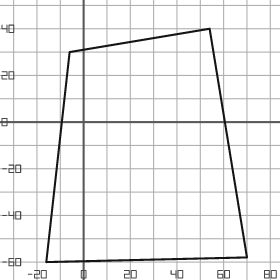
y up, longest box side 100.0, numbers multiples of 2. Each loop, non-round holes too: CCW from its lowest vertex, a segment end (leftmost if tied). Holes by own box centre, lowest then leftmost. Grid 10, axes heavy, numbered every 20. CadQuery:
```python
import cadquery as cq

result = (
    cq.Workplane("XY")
    .moveTo(-16.0, -60.0)
    .lineTo(70.0, -58.0)
    .lineTo(54.0, 40.0)
    .lineTo(-6.0, 30.0)
    .close()
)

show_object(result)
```